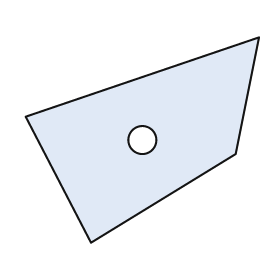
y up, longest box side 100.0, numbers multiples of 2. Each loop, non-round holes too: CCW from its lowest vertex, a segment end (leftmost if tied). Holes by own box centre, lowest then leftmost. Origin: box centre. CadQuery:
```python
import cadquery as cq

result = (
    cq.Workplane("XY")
    .moveTo(-22.0, -44.0)
    .lineTo(40.0, -6.0)
    .lineTo(50.0, 44.0)
    .lineTo(-50.0, 10.0)
    .close()
    .moveTo(0.0, 0.0)
    .circle(6.0)
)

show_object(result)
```